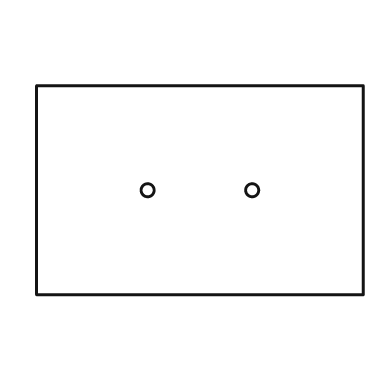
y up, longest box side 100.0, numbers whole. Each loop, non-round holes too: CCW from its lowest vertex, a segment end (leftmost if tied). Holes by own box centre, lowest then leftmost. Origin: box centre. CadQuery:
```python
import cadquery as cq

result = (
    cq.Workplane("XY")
    .moveTo(-50.0, -32.0)
    .lineTo(50.0, -32.0)
    .lineTo(50.0, 32.0)
    .lineTo(-50.0, 32.0)
    .close()
    .moveTo(-16.0, 0.0)
    .circle(2.0)
    .moveTo(16.0, 0.0)
    .circle(2.0)
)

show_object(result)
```